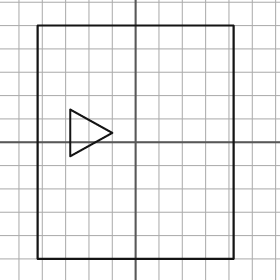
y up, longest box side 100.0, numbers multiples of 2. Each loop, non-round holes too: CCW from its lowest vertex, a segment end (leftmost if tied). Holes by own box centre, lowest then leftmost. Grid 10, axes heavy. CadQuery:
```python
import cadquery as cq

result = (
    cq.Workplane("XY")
    .moveTo(-42.0, -50.0)
    .lineTo(42.0, -50.0)
    .lineTo(42.0, 50.0)
    .lineTo(-42.0, 50.0)
    .close()
    .moveTo(-28.0, -6.0)
    .lineTo(-10.0, 4.0)
    .lineTo(-28.0, 14.0)
    .close()
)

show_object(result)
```